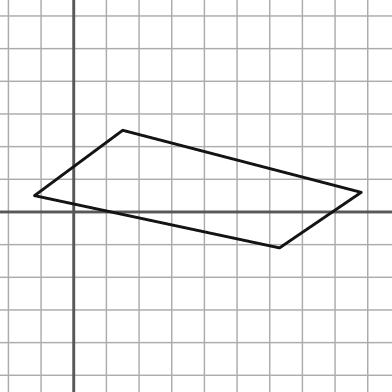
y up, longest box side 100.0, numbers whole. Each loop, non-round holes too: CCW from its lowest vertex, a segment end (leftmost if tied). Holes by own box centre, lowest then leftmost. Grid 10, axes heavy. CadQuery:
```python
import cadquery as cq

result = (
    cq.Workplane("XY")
    .moveTo(63.0, -11.0)
    .lineTo(88.0, 6.0)
    .lineTo(15.0, 25.0)
    .lineTo(-12.0, 5.0)
    .close()
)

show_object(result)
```